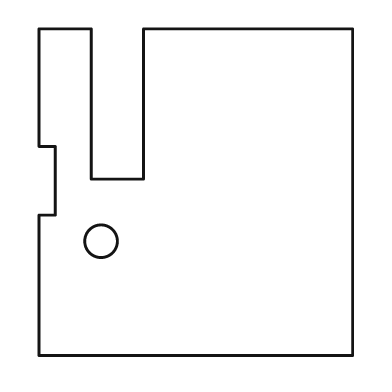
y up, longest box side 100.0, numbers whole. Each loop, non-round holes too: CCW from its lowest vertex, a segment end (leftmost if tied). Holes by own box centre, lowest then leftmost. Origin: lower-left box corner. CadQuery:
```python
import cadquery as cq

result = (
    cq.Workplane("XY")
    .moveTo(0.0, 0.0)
    .lineTo(96.0, 0.0)
    .lineTo(96.0, 100.0)
    .lineTo(32.0, 100.0)
    .lineTo(32.0, 54.0)
    .lineTo(16.0, 54.0)
    .lineTo(16.0, 100.0)
    .lineTo(0.0, 100.0)
    .lineTo(0.0, 64.0)
    .lineTo(5.0, 64.0)
    .lineTo(5.0, 43.0)
    .lineTo(0.0, 43.0)
    .close()
    .moveTo(19.0, 35.0)
    .circle(5.0)
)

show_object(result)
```